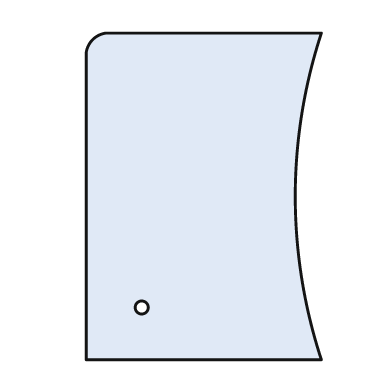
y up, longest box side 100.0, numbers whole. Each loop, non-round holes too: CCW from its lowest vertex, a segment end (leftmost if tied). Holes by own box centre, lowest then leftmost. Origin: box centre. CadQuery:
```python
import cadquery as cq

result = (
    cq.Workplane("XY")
    .moveTo(-36.0, -50.0)
    .lineTo(36.0, -50.0)
    .threePointArc((28.0, 0.0), (36.0, 50.0))
    .lineTo(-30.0, 50.0)
    .threePointArc((-34.0, 48.0), (-36.0, 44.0))
    .close()
    .moveTo(-19.0, -34.0)
    .circle(2.0)
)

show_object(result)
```